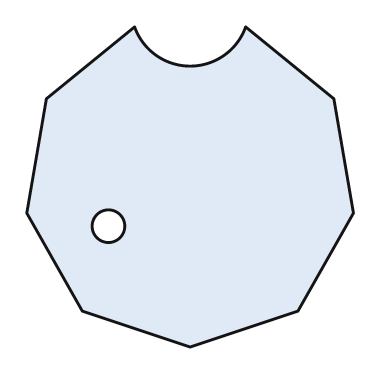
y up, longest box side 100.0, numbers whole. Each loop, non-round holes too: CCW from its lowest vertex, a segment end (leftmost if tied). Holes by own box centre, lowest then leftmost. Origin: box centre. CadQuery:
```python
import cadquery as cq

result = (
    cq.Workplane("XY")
    .moveTo(0.0, -49.0)
    .lineTo(33.0, -38.0)
    .lineTo(50.0, -8.0)
    .lineTo(44.0, 27.0)
    .lineTo(17.0, 49.0)
    .threePointArc((0.0, 37.0), (-17.0, 49.0))
    .lineTo(-44.0, 27.0)
    .lineTo(-50.0, -8.0)
    .lineTo(-33.0, -38.0)
    .close()
    .moveTo(-25.0, -12.0)
    .circle(5.0)
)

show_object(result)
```